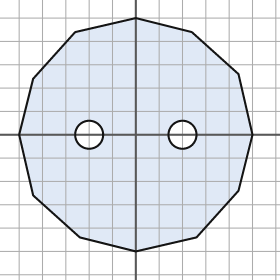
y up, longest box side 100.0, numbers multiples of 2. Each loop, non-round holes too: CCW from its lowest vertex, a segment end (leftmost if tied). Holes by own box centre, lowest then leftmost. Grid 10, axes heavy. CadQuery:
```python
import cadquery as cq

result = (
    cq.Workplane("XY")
    .moveTo(0.0, -50.0)
    .lineTo(26.0, -44.0)
    .lineTo(44.0, -24.0)
    .lineTo(50.0, 0.0)
    .lineTo(44.0, 26.0)
    .lineTo(24.0, 44.0)
    .lineTo(0.0, 50.0)
    .lineTo(-26.0, 44.0)
    .lineTo(-44.0, 24.0)
    .lineTo(-50.0, 0.0)
    .lineTo(-44.0, -26.0)
    .lineTo(-24.0, -44.0)
    .close()
    .moveTo(-20.0, 0.0)
    .circle(6.0)
    .moveTo(20.0, 0.0)
    .circle(6.0)
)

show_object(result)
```